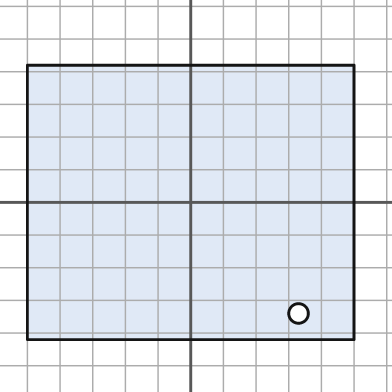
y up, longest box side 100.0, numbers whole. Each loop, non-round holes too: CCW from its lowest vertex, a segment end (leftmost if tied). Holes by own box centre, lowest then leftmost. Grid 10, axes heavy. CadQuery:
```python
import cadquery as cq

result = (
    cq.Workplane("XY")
    .moveTo(-50.0, -42.0)
    .lineTo(50.0, -42.0)
    .lineTo(50.0, 42.0)
    .lineTo(-50.0, 42.0)
    .close()
    .moveTo(33.0, -34.0)
    .circle(3.0)
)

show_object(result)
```